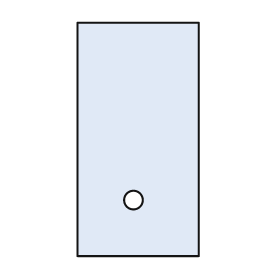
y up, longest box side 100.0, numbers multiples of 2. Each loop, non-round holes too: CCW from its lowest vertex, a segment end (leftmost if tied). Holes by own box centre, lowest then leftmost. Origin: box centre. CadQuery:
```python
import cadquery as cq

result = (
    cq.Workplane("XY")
    .moveTo(-26.0, -50.0)
    .lineTo(26.0, -50.0)
    .lineTo(26.0, 50.0)
    .lineTo(-26.0, 50.0)
    .close()
    .moveTo(-2.0, -26.0)
    .circle(4.0)
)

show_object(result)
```